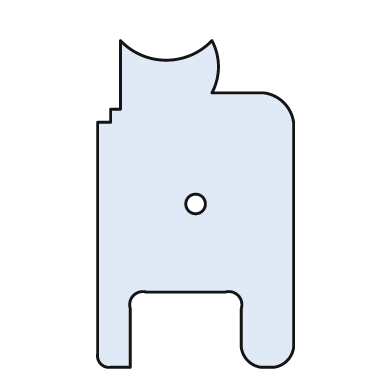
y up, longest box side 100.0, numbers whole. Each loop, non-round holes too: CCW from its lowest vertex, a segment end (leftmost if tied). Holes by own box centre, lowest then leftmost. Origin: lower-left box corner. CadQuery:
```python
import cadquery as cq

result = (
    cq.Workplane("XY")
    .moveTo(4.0, 0.0)
    .lineTo(10.0, 0.0)
    .lineTo(10.0, 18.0)
    .threePointArc((11.0, 22.0), (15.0, 23.0))
    .lineTo(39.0, 23.0)
    .threePointArc((43.0, 22.0), (44.0, 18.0))
    .lineTo(44.0, 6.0)
    .threePointArc((46.0, 2.0), (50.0, 0.0))
    .lineTo(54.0, 0.0)
    .threePointArc((58.0, 2.0), (60.0, 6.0))
    .lineTo(60.0, 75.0)
    .threePointArc((57.0, 81.0), (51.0, 84.0))
    .lineTo(35.0, 84.0)
    .threePointArc((37.0, 92.0), (35.0, 100.0))
    .threePointArc((21.0, 94.0), (7.0, 100.0))
    .lineTo(7.0, 79.0)
    .lineTo(4.0, 79.0)
    .lineTo(4.0, 75.0)
    .lineTo(0.0, 75.0)
    .lineTo(0.0, 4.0)
    .threePointArc((1.0, 1.0), (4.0, 0.0))
    .close()
    .moveTo(30.0, 50.0)
    .circle(3.0)
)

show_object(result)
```